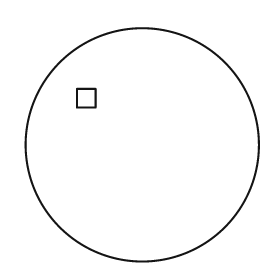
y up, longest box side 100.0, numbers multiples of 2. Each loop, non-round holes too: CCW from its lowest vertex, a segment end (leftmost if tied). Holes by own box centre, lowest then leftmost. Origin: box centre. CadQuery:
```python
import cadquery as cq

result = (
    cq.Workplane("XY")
    .moveTo(0.0, 0.0)
    .circle(50.0)
    .moveTo(-28.0, 16.0)
    .lineTo(-20.0, 16.0)
    .lineTo(-20.0, 24.0)
    .lineTo(-28.0, 24.0)
    .close()
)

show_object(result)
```